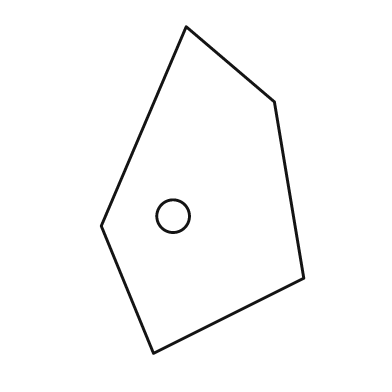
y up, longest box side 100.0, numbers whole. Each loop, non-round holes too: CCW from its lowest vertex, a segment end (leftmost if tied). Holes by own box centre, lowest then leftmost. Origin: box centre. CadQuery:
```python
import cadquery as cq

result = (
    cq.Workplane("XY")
    .moveTo(-15.0, -50.0)
    .lineTo(31.0, -27.0)
    .lineTo(22.0, 27.0)
    .lineTo(-5.0, 50.0)
    .lineTo(-31.0, -11.0)
    .close()
    .moveTo(-9.0, -8.0)
    .circle(5.0)
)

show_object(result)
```